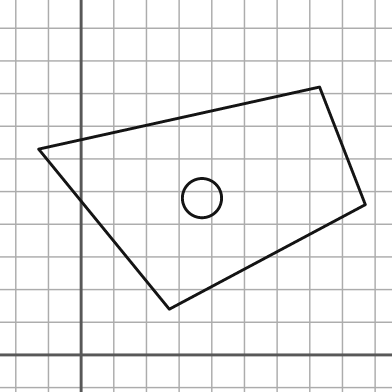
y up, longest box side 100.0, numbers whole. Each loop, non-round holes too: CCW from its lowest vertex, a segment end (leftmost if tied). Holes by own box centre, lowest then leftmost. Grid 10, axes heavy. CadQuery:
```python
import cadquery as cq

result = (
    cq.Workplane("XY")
    .moveTo(27.0, 14.0)
    .lineTo(87.0, 46.0)
    .lineTo(73.0, 82.0)
    .lineTo(-13.0, 63.0)
    .close()
    .moveTo(37.0, 48.0)
    .circle(6.0)
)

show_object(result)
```